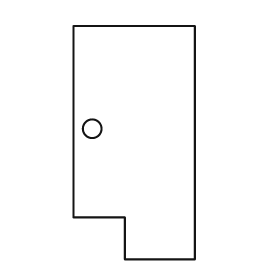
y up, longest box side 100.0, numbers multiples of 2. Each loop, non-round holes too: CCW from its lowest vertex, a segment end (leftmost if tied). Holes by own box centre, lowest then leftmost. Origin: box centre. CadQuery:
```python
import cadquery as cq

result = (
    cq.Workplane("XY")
    .moveTo(-4.0, -50.0)
    .lineTo(26.0, -50.0)
    .lineTo(26.0, 50.0)
    .lineTo(-26.0, 50.0)
    .lineTo(-26.0, -32.0)
    .lineTo(-4.0, -32.0)
    .close()
    .moveTo(-18.0, 6.0)
    .circle(4.0)
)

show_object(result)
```